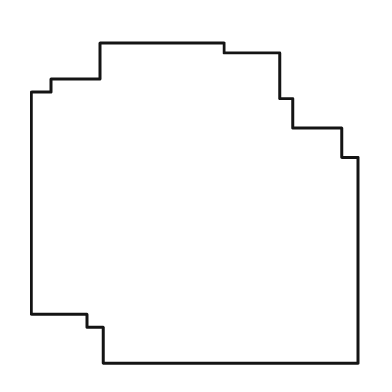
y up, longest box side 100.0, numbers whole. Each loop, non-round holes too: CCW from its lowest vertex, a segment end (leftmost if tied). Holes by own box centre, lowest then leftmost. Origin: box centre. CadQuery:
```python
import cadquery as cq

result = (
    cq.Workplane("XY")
    .moveTo(-28.0, -49.0)
    .lineTo(50.0, -49.0)
    .lineTo(50.0, 14.0)
    .lineTo(45.0, 14.0)
    .lineTo(45.0, 23.0)
    .lineTo(30.0, 23.0)
    .lineTo(30.0, 32.0)
    .lineTo(26.0, 32.0)
    .lineTo(26.0, 46.0)
    .lineTo(9.0, 46.0)
    .lineTo(9.0, 49.0)
    .lineTo(-29.0, 49.0)
    .lineTo(-29.0, 38.0)
    .lineTo(-44.0, 38.0)
    .lineTo(-44.0, 34.0)
    .lineTo(-50.0, 34.0)
    .lineTo(-50.0, -34.0)
    .lineTo(-33.0, -34.0)
    .lineTo(-33.0, -38.0)
    .lineTo(-28.0, -38.0)
    .close()
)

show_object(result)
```